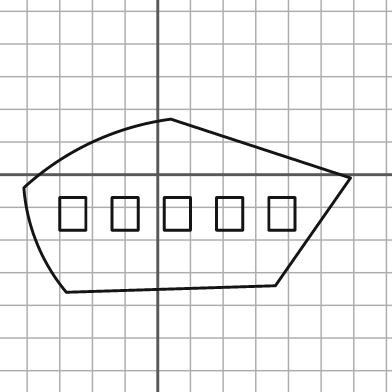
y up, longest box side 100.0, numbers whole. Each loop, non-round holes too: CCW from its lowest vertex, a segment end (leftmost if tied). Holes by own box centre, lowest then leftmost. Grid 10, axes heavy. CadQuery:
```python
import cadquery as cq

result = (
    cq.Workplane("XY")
    .moveTo(-28.0, -36.0)
    .lineTo(36.0, -34.0)
    .lineTo(59.0, -1.0)
    .lineTo(4.0, 17.0)
    .threePointArc((-20.0, 10.0), (-41.0, -4.0))
    .threePointArc((-37.0, -21.0), (-28.0, -36.0))
    .close()
    .moveTo(-30.0, -17.0)
    .lineTo(-22.0, -17.0)
    .lineTo(-22.0, -7.0)
    .lineTo(-30.0, -7.0)
    .close()
    .moveTo(-14.0, -17.0)
    .lineTo(-6.0, -17.0)
    .lineTo(-6.0, -7.0)
    .lineTo(-14.0, -7.0)
    .close()
    .moveTo(2.0, -17.0)
    .lineTo(10.0, -17.0)
    .lineTo(10.0, -7.0)
    .lineTo(2.0, -7.0)
    .close()
    .moveTo(18.0, -17.0)
    .lineTo(26.0, -17.0)
    .lineTo(26.0, -7.0)
    .lineTo(18.0, -7.0)
    .close()
    .moveTo(34.0, -17.0)
    .lineTo(42.0, -17.0)
    .lineTo(42.0, -7.0)
    .lineTo(34.0, -7.0)
    .close()
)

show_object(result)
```